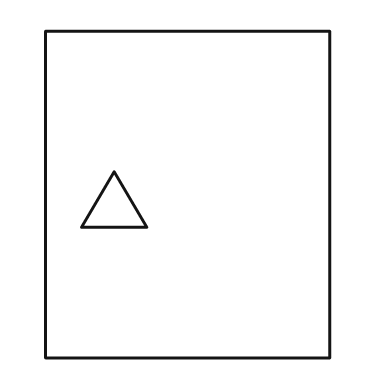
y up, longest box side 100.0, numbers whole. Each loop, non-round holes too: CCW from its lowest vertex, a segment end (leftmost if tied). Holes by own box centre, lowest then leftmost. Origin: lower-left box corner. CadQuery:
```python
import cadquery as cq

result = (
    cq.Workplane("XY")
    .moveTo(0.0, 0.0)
    .lineTo(87.0, 0.0)
    .lineTo(87.0, 100.0)
    .lineTo(0.0, 100.0)
    .close()
    .moveTo(11.0, 40.0)
    .lineTo(31.0, 40.0)
    .lineTo(21.0, 57.0)
    .close()
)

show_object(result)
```